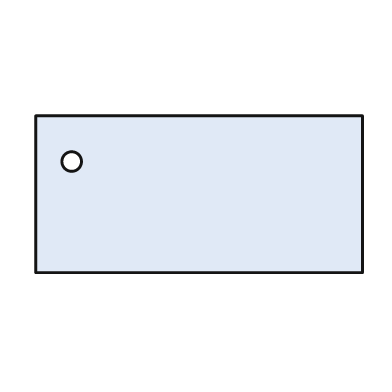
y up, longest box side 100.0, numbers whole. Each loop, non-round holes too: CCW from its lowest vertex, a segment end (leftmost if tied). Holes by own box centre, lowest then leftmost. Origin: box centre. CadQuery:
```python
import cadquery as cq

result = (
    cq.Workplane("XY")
    .moveTo(-50.0, -24.0)
    .lineTo(50.0, -24.0)
    .lineTo(50.0, 24.0)
    .lineTo(-50.0, 24.0)
    .close()
    .moveTo(-39.0, 10.0)
    .circle(3.0)
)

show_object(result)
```